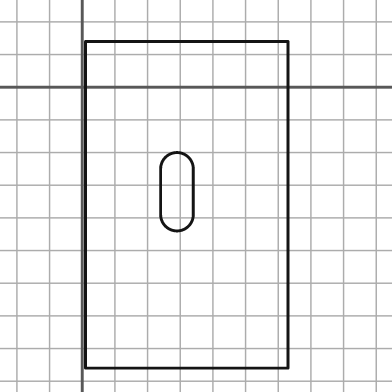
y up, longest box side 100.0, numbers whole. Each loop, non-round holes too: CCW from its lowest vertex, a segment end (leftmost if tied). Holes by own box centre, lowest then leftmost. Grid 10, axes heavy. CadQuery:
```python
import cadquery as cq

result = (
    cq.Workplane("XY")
    .moveTo(1.0, -86.0)
    .lineTo(63.0, -86.0)
    .lineTo(63.0, 14.0)
    .lineTo(1.0, 14.0)
    .close()
    .moveTo(24.0, -39.0)
    .threePointArc((29.0, -44.0), (34.0, -39.0))
    .lineTo(34.0, -25.0)
    .threePointArc((29.0, -20.0), (24.0, -25.0))
    .close()
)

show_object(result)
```